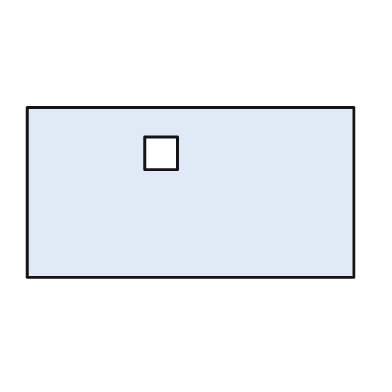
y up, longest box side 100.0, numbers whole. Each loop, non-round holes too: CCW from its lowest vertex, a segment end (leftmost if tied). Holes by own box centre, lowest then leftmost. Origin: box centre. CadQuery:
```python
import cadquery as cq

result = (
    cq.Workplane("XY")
    .moveTo(-50.0, -26.0)
    .lineTo(50.0, -26.0)
    .lineTo(50.0, 26.0)
    .lineTo(-50.0, 26.0)
    .close()
    .moveTo(-14.0, 7.0)
    .lineTo(-4.0, 7.0)
    .lineTo(-4.0, 17.0)
    .lineTo(-14.0, 17.0)
    .close()
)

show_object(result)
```